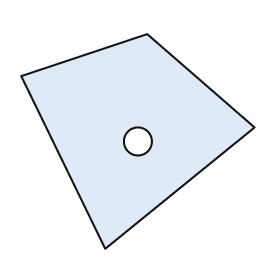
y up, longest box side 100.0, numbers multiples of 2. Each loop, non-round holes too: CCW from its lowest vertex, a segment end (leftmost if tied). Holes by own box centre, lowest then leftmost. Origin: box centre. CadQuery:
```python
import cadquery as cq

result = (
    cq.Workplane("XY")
    .moveTo(-14.0, -46.0)
    .lineTo(50.0, 6.0)
    .lineTo(4.0, 46.0)
    .lineTo(-50.0, 28.0)
    .close()
    .moveTo(0.0, 0.0)
    .circle(6.0)
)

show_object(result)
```